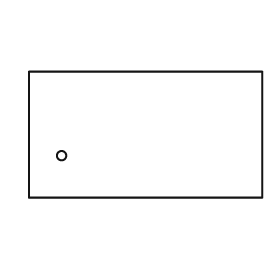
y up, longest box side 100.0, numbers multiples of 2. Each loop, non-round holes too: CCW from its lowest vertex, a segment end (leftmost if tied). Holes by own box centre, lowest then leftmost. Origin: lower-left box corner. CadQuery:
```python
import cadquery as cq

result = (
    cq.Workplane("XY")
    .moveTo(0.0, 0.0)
    .lineTo(100.0, 0.0)
    .lineTo(100.0, 54.0)
    .lineTo(0.0, 54.0)
    .close()
    .moveTo(14.0, 18.0)
    .circle(2.0)
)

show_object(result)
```